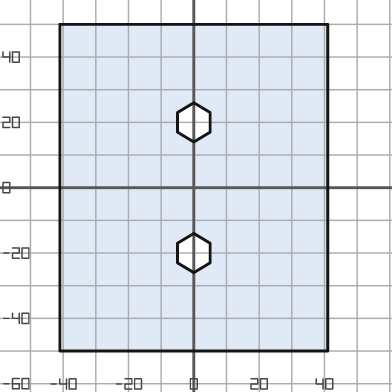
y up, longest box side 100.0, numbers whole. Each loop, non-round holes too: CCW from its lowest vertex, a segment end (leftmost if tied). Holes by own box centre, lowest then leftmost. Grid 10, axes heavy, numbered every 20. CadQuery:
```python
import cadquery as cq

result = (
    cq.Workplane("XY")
    .moveTo(-41.0, -50.0)
    .lineTo(41.0, -50.0)
    .lineTo(41.0, 50.0)
    .lineTo(-41.0, 50.0)
    .close()
    .moveTo(0.0, -26.0)
    .lineTo(5.0, -23.0)
    .lineTo(5.0, -17.0)
    .lineTo(0.0, -14.0)
    .lineTo(-5.0, -17.0)
    .lineTo(-5.0, -23.0)
    .close()
    .moveTo(0.0, 14.0)
    .lineTo(5.0, 17.0)
    .lineTo(5.0, 23.0)
    .lineTo(0.0, 26.0)
    .lineTo(-5.0, 23.0)
    .lineTo(-5.0, 17.0)
    .close()
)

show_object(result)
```